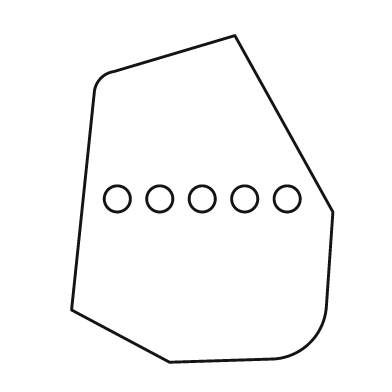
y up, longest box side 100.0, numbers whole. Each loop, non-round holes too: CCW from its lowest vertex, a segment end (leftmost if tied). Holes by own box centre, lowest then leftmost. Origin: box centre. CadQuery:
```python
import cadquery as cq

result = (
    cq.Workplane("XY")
    .moveTo(-10.0, -50.0)
    .lineTo(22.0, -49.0)
    .threePointArc((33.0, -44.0), (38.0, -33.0))
    .lineTo(40.0, -4.0)
    .lineTo(10.0, 50.0)
    .lineTo(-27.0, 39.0)
    .threePointArc((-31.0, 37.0), (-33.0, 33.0))
    .lineTo(-40.0, -34.0)
    .close()
    .moveTo(-26.0, 0.0)
    .circle(4.0)
    .moveTo(-13.0, 0.0)
    .circle(4.0)
    .moveTo(0.0, 0.0)
    .circle(4.0)
    .moveTo(13.0, 0.0)
    .circle(4.0)
    .moveTo(26.0, 0.0)
    .circle(4.0)
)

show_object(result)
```